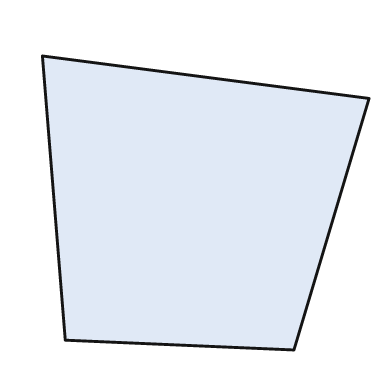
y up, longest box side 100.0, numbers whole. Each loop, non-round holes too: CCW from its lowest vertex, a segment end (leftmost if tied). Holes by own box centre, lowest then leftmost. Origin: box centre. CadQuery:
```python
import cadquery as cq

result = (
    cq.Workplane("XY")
    .moveTo(27.0, -45.0)
    .lineTo(50.0, 32.0)
    .lineTo(-50.0, 45.0)
    .lineTo(-43.0, -42.0)
    .close()
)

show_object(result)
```